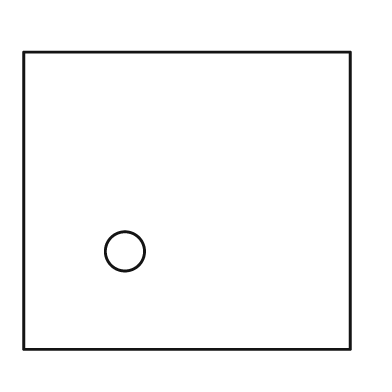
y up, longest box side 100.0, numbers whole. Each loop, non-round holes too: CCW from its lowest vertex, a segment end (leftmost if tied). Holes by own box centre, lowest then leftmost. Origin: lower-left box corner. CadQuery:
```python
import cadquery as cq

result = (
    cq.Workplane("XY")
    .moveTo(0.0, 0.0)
    .lineTo(100.0, 0.0)
    .lineTo(100.0, 91.0)
    .lineTo(0.0, 91.0)
    .close()
    .moveTo(31.0, 30.0)
    .circle(6.0)
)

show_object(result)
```